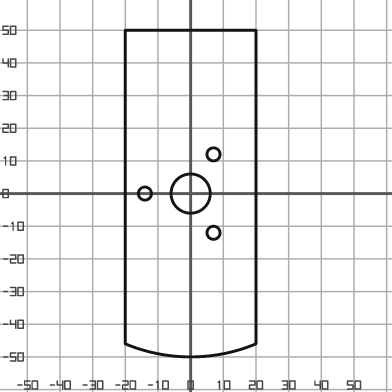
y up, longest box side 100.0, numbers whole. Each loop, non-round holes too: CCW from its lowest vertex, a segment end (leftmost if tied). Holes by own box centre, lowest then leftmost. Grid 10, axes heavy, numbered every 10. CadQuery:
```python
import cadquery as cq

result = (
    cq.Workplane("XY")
    .moveTo(-20.0, -46.0)
    .threePointArc((0.0, -50.0), (20.0, -46.0))
    .lineTo(20.0, 50.0)
    .lineTo(-20.0, 50.0)
    .close()
    .moveTo(7.0, -12.0)
    .circle(2.0)
    .moveTo(-14.0, 0.0)
    .circle(2.0)
    .moveTo(0.0, 0.0)
    .circle(6.0)
    .moveTo(7.0, 12.0)
    .circle(2.0)
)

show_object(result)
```